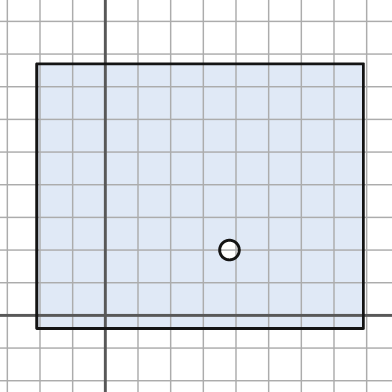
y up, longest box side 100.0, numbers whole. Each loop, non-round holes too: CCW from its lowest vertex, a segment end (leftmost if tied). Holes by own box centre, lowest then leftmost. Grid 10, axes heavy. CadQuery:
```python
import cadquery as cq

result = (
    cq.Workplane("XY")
    .moveTo(-21.0, -4.0)
    .lineTo(79.0, -4.0)
    .lineTo(79.0, 77.0)
    .lineTo(-21.0, 77.0)
    .close()
    .moveTo(38.0, 20.0)
    .circle(3.0)
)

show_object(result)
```